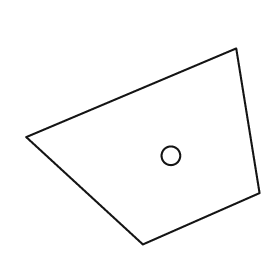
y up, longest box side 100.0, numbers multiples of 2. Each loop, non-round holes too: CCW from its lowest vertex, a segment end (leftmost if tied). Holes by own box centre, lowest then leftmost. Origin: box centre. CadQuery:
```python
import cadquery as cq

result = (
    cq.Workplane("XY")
    .moveTo(0.0, -42.0)
    .lineTo(50.0, -20.0)
    .lineTo(40.0, 42.0)
    .lineTo(-50.0, 4.0)
    .close()
    .moveTo(12.0, -4.0)
    .circle(4.0)
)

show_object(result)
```